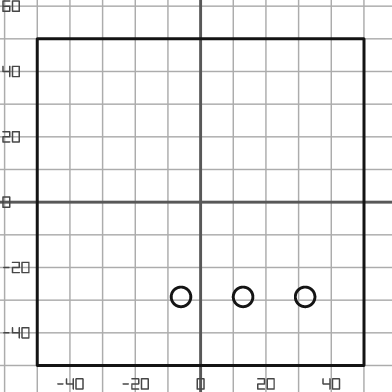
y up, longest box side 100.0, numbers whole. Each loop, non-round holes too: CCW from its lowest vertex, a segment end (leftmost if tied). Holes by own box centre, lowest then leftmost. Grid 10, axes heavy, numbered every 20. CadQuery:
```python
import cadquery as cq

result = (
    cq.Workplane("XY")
    .moveTo(-50.0, -50.0)
    .lineTo(50.0, -50.0)
    .lineTo(50.0, 50.0)
    .lineTo(-50.0, 50.0)
    .close()
    .moveTo(-6.0, -29.0)
    .circle(3.0)
    .moveTo(13.0, -29.0)
    .circle(3.0)
    .moveTo(32.0, -29.0)
    .circle(3.0)
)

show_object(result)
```